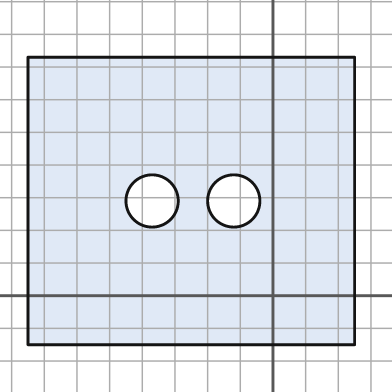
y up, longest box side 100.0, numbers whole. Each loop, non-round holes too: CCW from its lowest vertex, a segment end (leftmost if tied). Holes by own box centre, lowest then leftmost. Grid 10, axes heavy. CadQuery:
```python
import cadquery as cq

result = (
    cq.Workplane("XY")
    .moveTo(-75.0, -15.0)
    .lineTo(25.0, -15.0)
    .lineTo(25.0, 73.0)
    .lineTo(-75.0, 73.0)
    .close()
    .moveTo(-37.0, 29.0)
    .circle(8.0)
    .moveTo(-12.0, 29.0)
    .circle(8.0)
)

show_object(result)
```